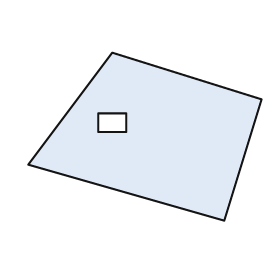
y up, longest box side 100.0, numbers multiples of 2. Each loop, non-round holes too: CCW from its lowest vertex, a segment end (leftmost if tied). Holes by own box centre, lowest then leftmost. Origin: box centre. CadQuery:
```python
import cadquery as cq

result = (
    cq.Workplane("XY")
    .moveTo(34.0, -36.0)
    .lineTo(50.0, 16.0)
    .lineTo(-14.0, 36.0)
    .lineTo(-50.0, -12.0)
    .close()
    .moveTo(-20.0, 2.0)
    .lineTo(-8.0, 2.0)
    .lineTo(-8.0, 10.0)
    .lineTo(-20.0, 10.0)
    .close()
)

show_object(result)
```